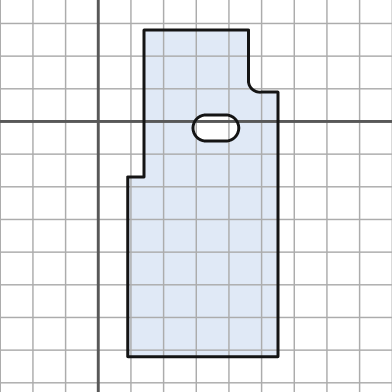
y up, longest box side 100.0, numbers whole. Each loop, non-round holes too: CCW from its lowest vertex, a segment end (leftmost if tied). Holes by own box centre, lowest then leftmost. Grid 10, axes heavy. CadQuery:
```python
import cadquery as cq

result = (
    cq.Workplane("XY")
    .moveTo(9.0, -72.0)
    .lineTo(55.0, -72.0)
    .lineTo(55.0, 9.0)
    .lineTo(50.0, 9.0)
    .threePointArc((47.0, 10.0), (46.0, 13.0))
    .lineTo(46.0, 28.0)
    .lineTo(14.0, 28.0)
    .lineTo(14.0, -17.0)
    .lineTo(9.0, -17.0)
    .close()
    .moveTo(33.0, -6.0)
    .lineTo(39.0, -6.0)
    .threePointArc((43.0, -2.0), (39.0, 2.0))
    .lineTo(33.0, 2.0)
    .threePointArc((29.0, -2.0), (33.0, -6.0))
    .close()
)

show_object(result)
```